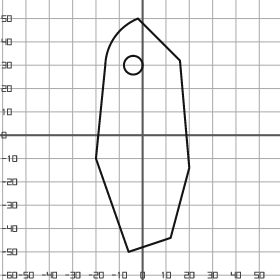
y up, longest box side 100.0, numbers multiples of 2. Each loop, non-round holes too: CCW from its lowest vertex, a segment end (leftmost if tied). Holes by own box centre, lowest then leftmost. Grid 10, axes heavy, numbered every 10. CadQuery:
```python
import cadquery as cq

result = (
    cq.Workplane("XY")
    .moveTo(-6.0, -50.0)
    .lineTo(12.0, -44.0)
    .lineTo(20.0, -14.0)
    .lineTo(16.0, 32.0)
    .lineTo(-2.0, 50.0)
    .threePointArc((-12.0, 42.0), (-16.0, 30.0))
    .lineTo(-20.0, -10.0)
    .close()
    .moveTo(-4.0, 30.0)
    .circle(4.0)
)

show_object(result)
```